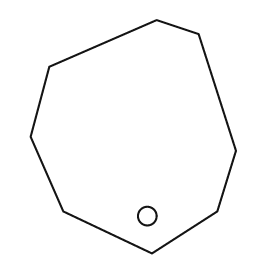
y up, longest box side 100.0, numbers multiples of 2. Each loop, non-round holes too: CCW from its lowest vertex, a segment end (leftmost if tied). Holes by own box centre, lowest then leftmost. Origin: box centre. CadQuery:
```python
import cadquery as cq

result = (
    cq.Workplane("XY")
    .moveTo(8.0, -50.0)
    .lineTo(36.0, -32.0)
    .lineTo(44.0, -6.0)
    .lineTo(28.0, 44.0)
    .lineTo(10.0, 50.0)
    .lineTo(-36.0, 30.0)
    .lineTo(-44.0, 0.0)
    .lineTo(-30.0, -32.0)
    .close()
    .moveTo(6.0, -34.0)
    .circle(4.0)
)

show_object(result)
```